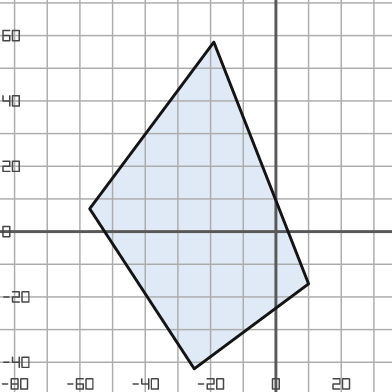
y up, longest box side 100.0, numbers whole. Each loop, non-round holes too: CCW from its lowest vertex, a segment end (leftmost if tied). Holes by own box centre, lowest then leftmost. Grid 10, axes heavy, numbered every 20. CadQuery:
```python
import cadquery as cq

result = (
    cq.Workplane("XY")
    .moveTo(-25.0, -42.0)
    .lineTo(10.0, -16.0)
    .lineTo(-19.0, 58.0)
    .lineTo(-57.0, 7.0)
    .close()
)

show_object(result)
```